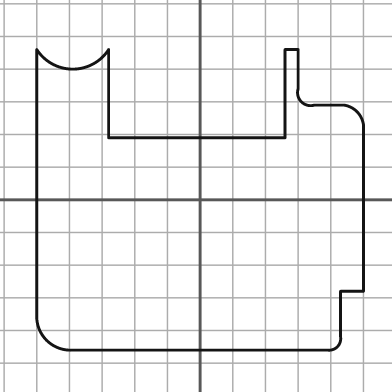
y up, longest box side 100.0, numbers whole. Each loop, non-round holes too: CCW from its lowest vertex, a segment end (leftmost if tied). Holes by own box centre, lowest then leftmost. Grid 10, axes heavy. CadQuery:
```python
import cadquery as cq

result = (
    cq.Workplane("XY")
    .moveTo(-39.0, -46.0)
    .lineTo(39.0, -46.0)
    .threePointArc((42.0, -45.0), (43.0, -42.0))
    .lineTo(43.0, -28.0)
    .lineTo(50.0, -28.0)
    .lineTo(50.0, 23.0)
    .threePointArc((48.0, 27.0), (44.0, 29.0))
    .lineTo(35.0, 29.0)
    .threePointArc((31.0, 30.0), (30.0, 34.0))
    .lineTo(30.0, 46.0)
    .lineTo(26.0, 46.0)
    .lineTo(26.0, 19.0)
    .lineTo(-28.0, 19.0)
    .lineTo(-28.0, 46.0)
    .threePointArc((-39.0, 40.0), (-50.0, 46.0))
    .lineTo(-50.0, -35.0)
    .threePointArc((-47.0, -43.0), (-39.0, -46.0))
    .close()
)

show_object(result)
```